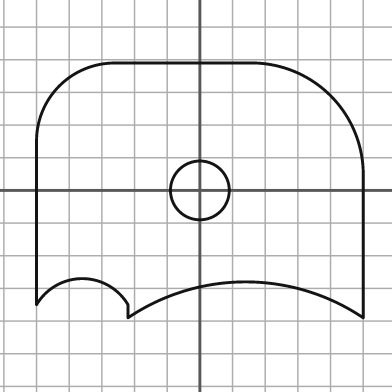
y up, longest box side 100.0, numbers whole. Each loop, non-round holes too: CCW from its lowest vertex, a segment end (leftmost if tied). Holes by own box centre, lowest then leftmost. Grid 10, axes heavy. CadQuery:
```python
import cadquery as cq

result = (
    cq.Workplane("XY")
    .moveTo(-22.0, -39.0)
    .threePointArc((14.0, -28.0), (50.0, -39.0))
    .lineTo(50.0, 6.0)
    .threePointArc((40.0, 29.0), (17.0, 39.0))
    .lineTo(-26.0, 39.0)
    .threePointArc((-43.0, 32.0), (-50.0, 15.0))
    .lineTo(-50.0, -35.0)
    .threePointArc((-36.0, -27.0), (-22.0, -35.0))
    .close()
    .moveTo(0.0, 0.0)
    .circle(9.0)
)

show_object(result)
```